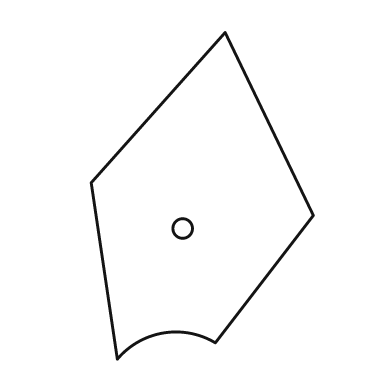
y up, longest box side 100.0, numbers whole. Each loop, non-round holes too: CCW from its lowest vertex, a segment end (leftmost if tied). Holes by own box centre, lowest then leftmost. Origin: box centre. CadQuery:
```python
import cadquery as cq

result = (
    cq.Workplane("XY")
    .moveTo(-26.0, -50.0)
    .threePointArc((-12.0, -42.0), (4.0, -45.0))
    .lineTo(34.0, -6.0)
    .lineTo(7.0, 50.0)
    .lineTo(-34.0, 4.0)
    .close()
    .moveTo(-6.0, -10.0)
    .circle(3.0)
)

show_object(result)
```